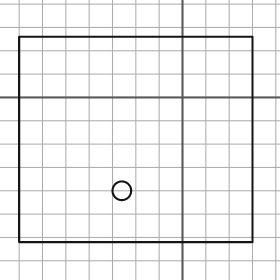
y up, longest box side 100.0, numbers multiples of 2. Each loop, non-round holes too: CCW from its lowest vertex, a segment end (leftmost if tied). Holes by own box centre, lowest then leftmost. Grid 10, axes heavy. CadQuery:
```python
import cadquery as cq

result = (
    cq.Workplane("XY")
    .moveTo(-70.0, -62.0)
    .lineTo(30.0, -62.0)
    .lineTo(30.0, 26.0)
    .lineTo(-70.0, 26.0)
    .close()
    .moveTo(-26.0, -40.0)
    .circle(4.0)
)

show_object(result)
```